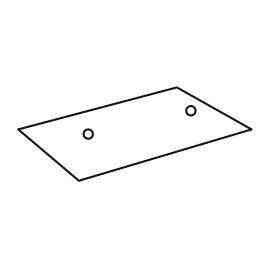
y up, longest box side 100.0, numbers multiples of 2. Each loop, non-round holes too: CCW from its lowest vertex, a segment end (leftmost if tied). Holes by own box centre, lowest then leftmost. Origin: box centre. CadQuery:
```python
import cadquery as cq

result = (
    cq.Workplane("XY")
    .moveTo(-24.0, -20.0)
    .lineTo(50.0, 2.0)
    .lineTo(18.0, 20.0)
    .lineTo(-50.0, 2.0)
    .close()
    .moveTo(-20.0, 0.0)
    .circle(2.0)
    .moveTo(24.0, 10.0)
    .circle(2.0)
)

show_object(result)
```